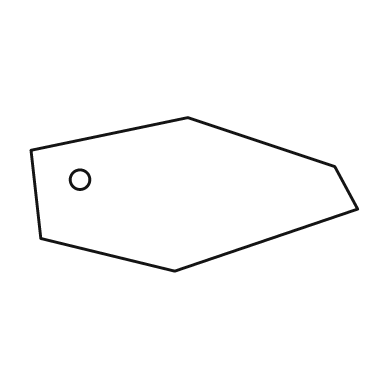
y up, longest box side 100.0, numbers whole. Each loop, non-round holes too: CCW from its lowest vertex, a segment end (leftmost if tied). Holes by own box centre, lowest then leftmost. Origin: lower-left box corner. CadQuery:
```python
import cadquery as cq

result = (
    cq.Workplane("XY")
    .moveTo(44.0, 0.0)
    .lineTo(100.0, 19.0)
    .lineTo(93.0, 32.0)
    .lineTo(48.0, 47.0)
    .lineTo(0.0, 37.0)
    .lineTo(3.0, 10.0)
    .close()
    .moveTo(15.0, 28.0)
    .circle(3.0)
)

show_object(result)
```